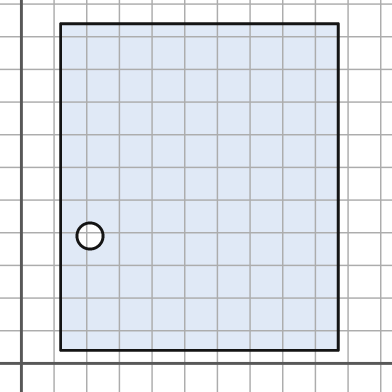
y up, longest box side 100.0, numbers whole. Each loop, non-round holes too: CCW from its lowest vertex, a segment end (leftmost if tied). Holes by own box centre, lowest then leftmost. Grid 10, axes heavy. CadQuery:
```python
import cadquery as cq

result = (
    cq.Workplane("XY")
    .moveTo(12.0, 4.0)
    .lineTo(97.0, 4.0)
    .lineTo(97.0, 104.0)
    .lineTo(12.0, 104.0)
    .close()
    .moveTo(21.0, 39.0)
    .circle(4.0)
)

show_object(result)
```